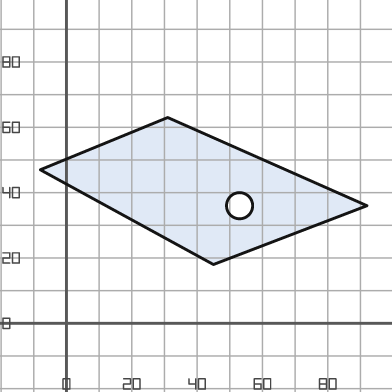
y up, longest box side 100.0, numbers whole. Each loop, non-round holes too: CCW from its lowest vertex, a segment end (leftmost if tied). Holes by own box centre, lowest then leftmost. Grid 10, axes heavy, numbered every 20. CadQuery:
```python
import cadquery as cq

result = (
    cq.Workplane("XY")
    .moveTo(45.0, 18.0)
    .lineTo(92.0, 36.0)
    .lineTo(31.0, 63.0)
    .lineTo(-8.0, 47.0)
    .close()
    .moveTo(53.0, 36.0)
    .circle(4.0)
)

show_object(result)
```